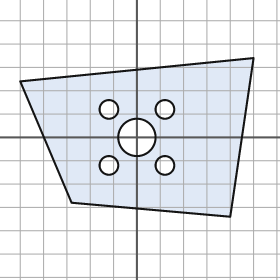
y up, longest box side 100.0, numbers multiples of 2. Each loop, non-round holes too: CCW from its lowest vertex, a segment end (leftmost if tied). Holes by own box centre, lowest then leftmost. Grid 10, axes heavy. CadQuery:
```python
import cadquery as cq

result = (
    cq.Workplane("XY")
    .moveTo(40.0, -34.0)
    .lineTo(50.0, 34.0)
    .lineTo(-50.0, 24.0)
    .lineTo(-28.0, -28.0)
    .close()
    .moveTo(-12.0, -12.0)
    .circle(4.0)
    .moveTo(12.0, -12.0)
    .circle(4.0)
    .moveTo(0.0, 0.0)
    .circle(8.0)
    .moveTo(-12.0, 12.0)
    .circle(4.0)
    .moveTo(12.0, 12.0)
    .circle(4.0)
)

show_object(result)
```